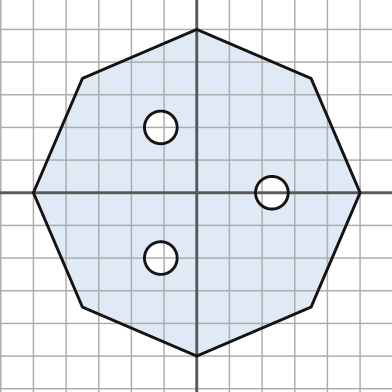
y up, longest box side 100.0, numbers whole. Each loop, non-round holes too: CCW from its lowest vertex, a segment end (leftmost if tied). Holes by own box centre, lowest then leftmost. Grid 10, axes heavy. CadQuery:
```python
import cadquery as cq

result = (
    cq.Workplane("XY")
    .moveTo(0.0, -50.0)
    .lineTo(35.0, -35.0)
    .lineTo(50.0, 0.0)
    .lineTo(35.0, 35.0)
    .lineTo(0.0, 50.0)
    .lineTo(-35.0, 35.0)
    .lineTo(-50.0, 0.0)
    .lineTo(-35.0, -35.0)
    .close()
    .moveTo(-11.0, -20.0)
    .circle(5.0)
    .moveTo(23.0, 0.0)
    .circle(5.0)
    .moveTo(-11.0, 20.0)
    .circle(5.0)
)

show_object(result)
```